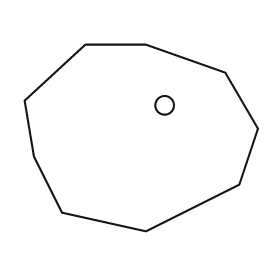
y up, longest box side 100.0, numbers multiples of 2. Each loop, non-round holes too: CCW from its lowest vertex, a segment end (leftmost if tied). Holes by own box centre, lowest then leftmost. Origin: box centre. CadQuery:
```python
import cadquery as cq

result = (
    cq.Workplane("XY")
    .moveTo(2.0, -40.0)
    .lineTo(42.0, -20.0)
    .lineTo(50.0, 4.0)
    .lineTo(36.0, 28.0)
    .lineTo(2.0, 40.0)
    .lineTo(-24.0, 40.0)
    .lineTo(-50.0, 16.0)
    .lineTo(-46.0, -8.0)
    .lineTo(-34.0, -32.0)
    .close()
    .moveTo(10.0, 14.0)
    .circle(4.0)
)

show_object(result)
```